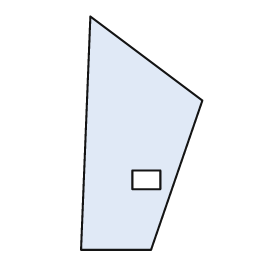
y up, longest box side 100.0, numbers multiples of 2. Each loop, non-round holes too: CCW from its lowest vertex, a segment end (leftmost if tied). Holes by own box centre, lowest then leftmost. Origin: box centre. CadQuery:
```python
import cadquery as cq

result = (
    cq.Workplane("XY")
    .moveTo(-26.0, -50.0)
    .lineTo(4.0, -50.0)
    .lineTo(26.0, 14.0)
    .lineTo(-22.0, 50.0)
    .close()
    .moveTo(-4.0, -24.0)
    .lineTo(8.0, -24.0)
    .lineTo(8.0, -16.0)
    .lineTo(-4.0, -16.0)
    .close()
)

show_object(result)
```